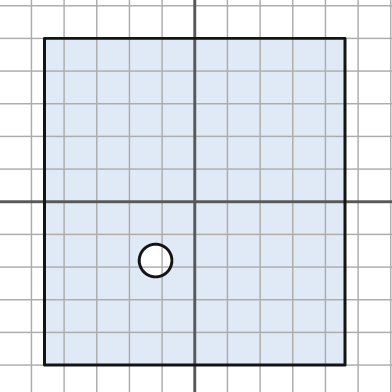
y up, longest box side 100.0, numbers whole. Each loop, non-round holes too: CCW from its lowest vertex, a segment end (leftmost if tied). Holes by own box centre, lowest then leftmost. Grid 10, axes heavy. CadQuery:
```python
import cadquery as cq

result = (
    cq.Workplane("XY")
    .moveTo(-46.0, -50.0)
    .lineTo(46.0, -50.0)
    .lineTo(46.0, 50.0)
    .lineTo(-46.0, 50.0)
    .close()
    .moveTo(-12.0, -18.0)
    .circle(5.0)
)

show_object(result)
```